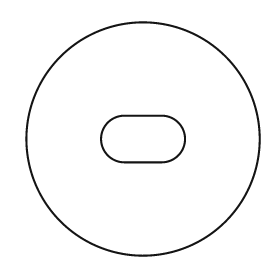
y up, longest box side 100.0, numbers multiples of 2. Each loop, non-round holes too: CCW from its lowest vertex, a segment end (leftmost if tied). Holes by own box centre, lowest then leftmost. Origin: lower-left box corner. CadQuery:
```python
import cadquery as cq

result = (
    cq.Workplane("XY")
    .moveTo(50.0, 50.0)
    .circle(50.0)
    .moveTo(42.0, 40.0)
    .lineTo(58.0, 40.0)
    .threePointArc((68.0, 50.0), (58.0, 60.0))
    .lineTo(42.0, 60.0)
    .threePointArc((32.0, 50.0), (42.0, 40.0))
    .close()
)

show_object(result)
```